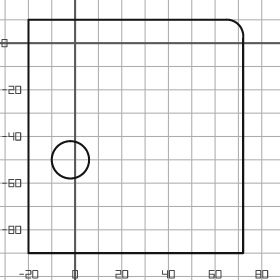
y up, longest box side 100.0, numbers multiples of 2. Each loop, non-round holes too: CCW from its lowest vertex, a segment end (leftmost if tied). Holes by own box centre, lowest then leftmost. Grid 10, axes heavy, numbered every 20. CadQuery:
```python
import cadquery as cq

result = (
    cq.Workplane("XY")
    .moveTo(-20.0, -90.0)
    .lineTo(72.0, -90.0)
    .lineTo(72.0, 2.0)
    .threePointArc((70.0, 8.0), (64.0, 10.0))
    .lineTo(-20.0, 10.0)
    .close()
    .moveTo(-2.0, -50.0)
    .circle(8.0)
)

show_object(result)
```